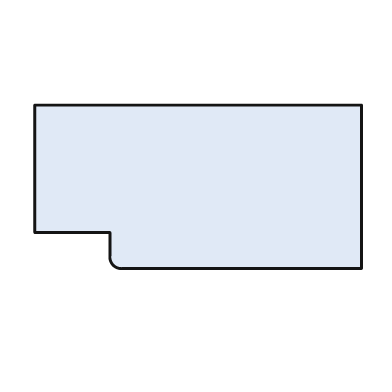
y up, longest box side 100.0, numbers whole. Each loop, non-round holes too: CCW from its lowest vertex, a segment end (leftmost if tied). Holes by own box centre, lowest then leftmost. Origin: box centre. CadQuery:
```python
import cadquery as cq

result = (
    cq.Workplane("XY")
    .moveTo(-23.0, -25.0)
    .lineTo(50.0, -25.0)
    .lineTo(50.0, 25.0)
    .lineTo(-50.0, 25.0)
    .lineTo(-50.0, -14.0)
    .lineTo(-27.0, -14.0)
    .lineTo(-27.0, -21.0)
    .threePointArc((-26.0, -24.0), (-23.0, -25.0))
    .close()
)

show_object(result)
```